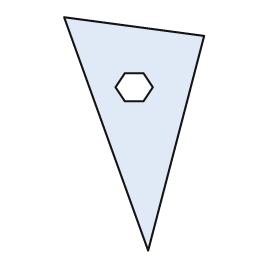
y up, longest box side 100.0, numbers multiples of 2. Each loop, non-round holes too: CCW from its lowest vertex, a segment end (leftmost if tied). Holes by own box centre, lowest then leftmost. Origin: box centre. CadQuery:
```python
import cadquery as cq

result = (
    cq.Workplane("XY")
    .moveTo(6.0, -50.0)
    .lineTo(30.0, 42.0)
    .lineTo(-30.0, 50.0)
    .close()
    .moveTo(-4.0, 14.0)
    .lineTo(4.0, 14.0)
    .lineTo(8.0, 20.0)
    .lineTo(4.0, 26.0)
    .lineTo(-4.0, 26.0)
    .lineTo(-8.0, 20.0)
    .close()
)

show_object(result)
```